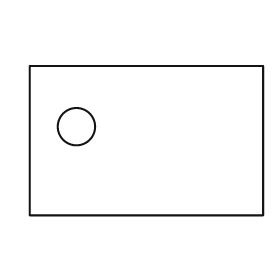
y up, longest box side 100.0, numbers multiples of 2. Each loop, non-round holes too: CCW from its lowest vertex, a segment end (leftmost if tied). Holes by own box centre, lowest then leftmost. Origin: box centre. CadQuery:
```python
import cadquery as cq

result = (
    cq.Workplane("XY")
    .moveTo(-50.0, -32.0)
    .lineTo(50.0, -32.0)
    .lineTo(50.0, 32.0)
    .lineTo(-50.0, 32.0)
    .close()
    .moveTo(-30.0, 6.0)
    .circle(8.0)
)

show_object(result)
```